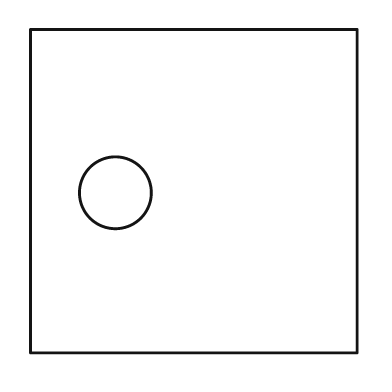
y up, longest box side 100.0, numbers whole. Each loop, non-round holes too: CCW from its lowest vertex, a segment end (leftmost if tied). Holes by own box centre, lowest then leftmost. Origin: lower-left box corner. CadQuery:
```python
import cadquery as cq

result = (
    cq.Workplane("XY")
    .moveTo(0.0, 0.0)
    .lineTo(100.0, 0.0)
    .lineTo(100.0, 99.0)
    .lineTo(0.0, 99.0)
    .close()
    .moveTo(26.0, 49.0)
    .circle(11.0)
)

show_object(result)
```